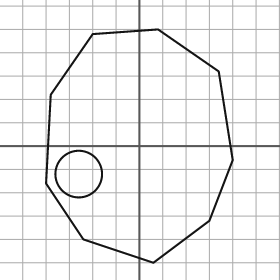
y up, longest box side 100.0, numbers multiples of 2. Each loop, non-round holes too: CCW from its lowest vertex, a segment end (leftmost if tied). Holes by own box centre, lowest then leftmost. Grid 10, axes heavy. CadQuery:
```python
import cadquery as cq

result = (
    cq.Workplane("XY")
    .moveTo(6.0, -50.0)
    .lineTo(30.0, -32.0)
    .lineTo(40.0, -6.0)
    .lineTo(34.0, 32.0)
    .lineTo(8.0, 50.0)
    .lineTo(-20.0, 48.0)
    .lineTo(-38.0, 22.0)
    .lineTo(-40.0, -16.0)
    .lineTo(-24.0, -40.0)
    .close()
    .moveTo(-26.0, -12.0)
    .circle(10.0)
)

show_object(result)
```